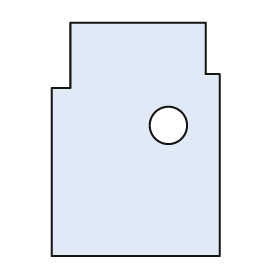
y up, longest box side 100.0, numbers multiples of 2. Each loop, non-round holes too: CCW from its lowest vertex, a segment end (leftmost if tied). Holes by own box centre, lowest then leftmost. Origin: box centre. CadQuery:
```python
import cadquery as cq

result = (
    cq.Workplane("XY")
    .moveTo(-36.0, -50.0)
    .lineTo(36.0, -50.0)
    .lineTo(36.0, 28.0)
    .lineTo(30.0, 28.0)
    .lineTo(30.0, 50.0)
    .lineTo(-28.0, 50.0)
    .lineTo(-28.0, 22.0)
    .lineTo(-36.0, 22.0)
    .close()
    .moveTo(14.0, 6.0)
    .circle(8.0)
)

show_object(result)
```